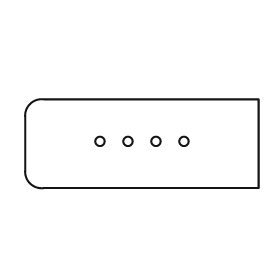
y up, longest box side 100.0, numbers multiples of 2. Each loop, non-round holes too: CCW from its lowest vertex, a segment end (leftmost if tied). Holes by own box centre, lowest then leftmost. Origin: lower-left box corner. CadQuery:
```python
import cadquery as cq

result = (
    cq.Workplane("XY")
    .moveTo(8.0, 0.0)
    .lineTo(100.0, 0.0)
    .lineTo(100.0, 38.0)
    .lineTo(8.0, 38.0)
    .threePointArc((2.0, 36.0), (0.0, 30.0))
    .lineTo(0.0, 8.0)
    .threePointArc((2.0, 2.0), (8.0, 0.0))
    .close()
    .moveTo(32.0, 20.0)
    .circle(2.0)
    .moveTo(44.0, 20.0)
    .circle(2.0)
    .moveTo(56.0, 20.0)
    .circle(2.0)
    .moveTo(68.0, 20.0)
    .circle(2.0)
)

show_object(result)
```